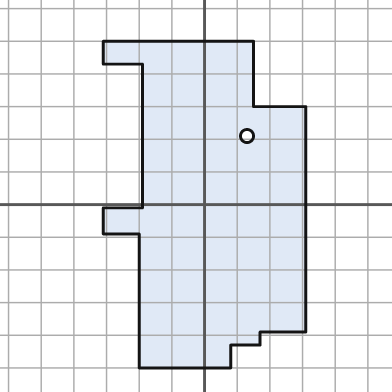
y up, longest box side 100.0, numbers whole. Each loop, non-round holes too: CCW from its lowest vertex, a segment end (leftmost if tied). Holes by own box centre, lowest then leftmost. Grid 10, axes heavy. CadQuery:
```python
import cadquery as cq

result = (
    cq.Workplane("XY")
    .moveTo(-20.0, -50.0)
    .lineTo(8.0, -50.0)
    .lineTo(8.0, -43.0)
    .lineTo(17.0, -43.0)
    .lineTo(17.0, -39.0)
    .lineTo(31.0, -39.0)
    .lineTo(31.0, 30.0)
    .lineTo(15.0, 30.0)
    .lineTo(15.0, 50.0)
    .lineTo(-31.0, 50.0)
    .lineTo(-31.0, 43.0)
    .lineTo(-19.0, 43.0)
    .lineTo(-19.0, -1.0)
    .lineTo(-31.0, -1.0)
    .lineTo(-31.0, -9.0)
    .lineTo(-20.0, -9.0)
    .close()
    .moveTo(13.0, 21.0)
    .circle(2.0)
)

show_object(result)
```